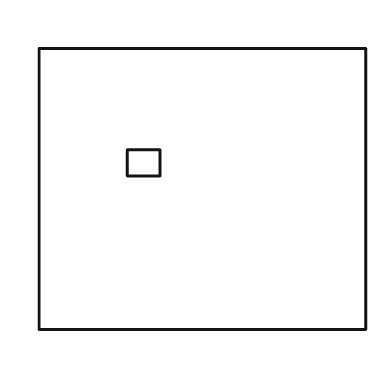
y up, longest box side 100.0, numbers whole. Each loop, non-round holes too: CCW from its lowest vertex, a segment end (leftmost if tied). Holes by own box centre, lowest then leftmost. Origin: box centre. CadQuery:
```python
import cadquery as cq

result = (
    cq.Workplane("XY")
    .moveTo(-50.0, -43.0)
    .lineTo(50.0, -43.0)
    .lineTo(50.0, 43.0)
    .lineTo(-50.0, 43.0)
    .close()
    .moveTo(-23.0, 4.0)
    .lineTo(-13.0, 4.0)
    .lineTo(-13.0, 12.0)
    .lineTo(-23.0, 12.0)
    .close()
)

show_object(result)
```